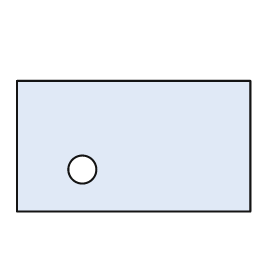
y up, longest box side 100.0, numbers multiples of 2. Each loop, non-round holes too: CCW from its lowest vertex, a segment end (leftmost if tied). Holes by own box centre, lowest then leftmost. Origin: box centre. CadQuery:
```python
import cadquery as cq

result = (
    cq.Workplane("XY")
    .moveTo(-50.0, -28.0)
    .lineTo(50.0, -28.0)
    .lineTo(50.0, 28.0)
    .lineTo(-50.0, 28.0)
    .close()
    .moveTo(-22.0, -10.0)
    .circle(6.0)
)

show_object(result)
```